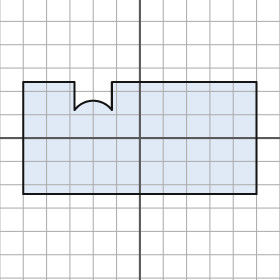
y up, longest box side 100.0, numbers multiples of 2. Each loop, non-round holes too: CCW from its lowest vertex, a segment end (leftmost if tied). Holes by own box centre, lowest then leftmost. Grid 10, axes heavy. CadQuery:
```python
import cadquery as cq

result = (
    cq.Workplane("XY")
    .moveTo(-50.0, -24.0)
    .lineTo(50.0, -24.0)
    .lineTo(50.0, 24.0)
    .lineTo(-12.0, 24.0)
    .lineTo(-12.0, 12.0)
    .threePointArc((-20.0, 16.0), (-28.0, 12.0))
    .lineTo(-28.0, 24.0)
    .lineTo(-50.0, 24.0)
    .close()
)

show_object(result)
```